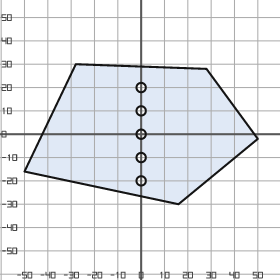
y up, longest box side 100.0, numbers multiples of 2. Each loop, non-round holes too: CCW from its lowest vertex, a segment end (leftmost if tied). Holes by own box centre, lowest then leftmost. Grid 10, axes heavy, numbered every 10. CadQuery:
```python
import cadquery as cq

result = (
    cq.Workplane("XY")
    .moveTo(16.0, -30.0)
    .lineTo(50.0, -2.0)
    .lineTo(28.0, 28.0)
    .lineTo(-28.0, 30.0)
    .lineTo(-50.0, -16.0)
    .close()
    .moveTo(0.0, -20.0)
    .circle(2.0)
    .moveTo(0.0, -10.0)
    .circle(2.0)
    .moveTo(0.0, 0.0)
    .circle(2.0)
    .moveTo(0.0, 10.0)
    .circle(2.0)
    .moveTo(0.0, 20.0)
    .circle(2.0)
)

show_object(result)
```